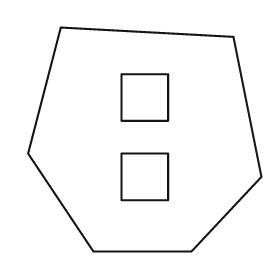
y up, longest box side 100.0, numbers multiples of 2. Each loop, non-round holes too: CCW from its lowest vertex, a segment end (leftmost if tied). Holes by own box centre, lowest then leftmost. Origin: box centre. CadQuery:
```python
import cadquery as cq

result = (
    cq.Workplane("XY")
    .moveTo(-22.0, -48.0)
    .lineTo(20.0, -48.0)
    .lineTo(50.0, -16.0)
    .lineTo(38.0, 44.0)
    .lineTo(-36.0, 48.0)
    .lineTo(-50.0, -6.0)
    .close()
    .moveTo(-10.0, -26.0)
    .lineTo(10.0, -26.0)
    .lineTo(10.0, -6.0)
    .lineTo(-10.0, -6.0)
    .close()
    .moveTo(-10.0, 8.0)
    .lineTo(10.0, 8.0)
    .lineTo(10.0, 28.0)
    .lineTo(-10.0, 28.0)
    .close()
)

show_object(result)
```